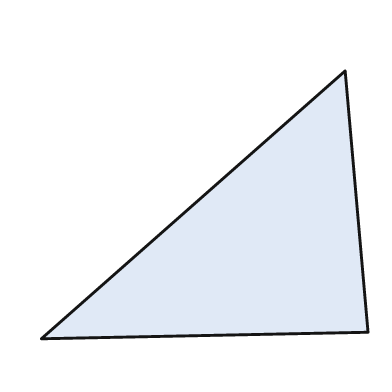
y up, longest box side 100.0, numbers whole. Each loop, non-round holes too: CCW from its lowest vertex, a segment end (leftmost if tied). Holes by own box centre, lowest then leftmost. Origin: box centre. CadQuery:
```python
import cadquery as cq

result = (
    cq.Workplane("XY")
    .moveTo(-50.0, -41.0)
    .lineTo(50.0, -39.0)
    .lineTo(43.0, 41.0)
    .close()
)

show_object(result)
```